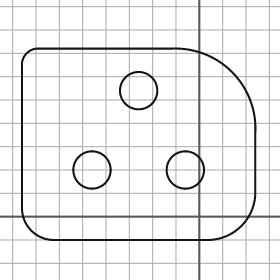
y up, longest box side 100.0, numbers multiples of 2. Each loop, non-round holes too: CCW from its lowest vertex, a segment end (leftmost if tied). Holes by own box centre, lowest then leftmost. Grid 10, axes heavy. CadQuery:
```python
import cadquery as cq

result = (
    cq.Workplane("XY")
    .moveTo(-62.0, -10.0)
    .lineTo(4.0, -10.0)
    .threePointArc((18.0, -4.0), (24.0, 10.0))
    .lineTo(24.0, 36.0)
    .threePointArc((14.0, 62.0), (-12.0, 72.0))
    .lineTo(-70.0, 72.0)
    .threePointArc((-74.0, 70.0), (-76.0, 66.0))
    .lineTo(-76.0, 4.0)
    .threePointArc((-72.0, -6.0), (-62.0, -10.0))
    .close()
    .moveTo(-46.0, 20.0)
    .circle(8.0)
    .moveTo(-6.0, 20.0)
    .circle(8.0)
    .moveTo(-26.0, 54.0)
    .circle(8.0)
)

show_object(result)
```